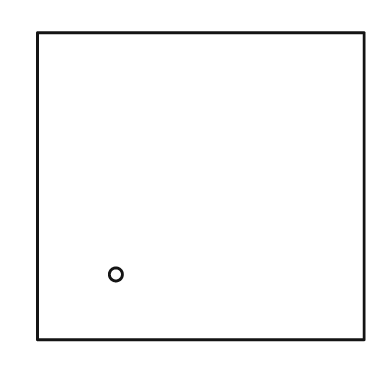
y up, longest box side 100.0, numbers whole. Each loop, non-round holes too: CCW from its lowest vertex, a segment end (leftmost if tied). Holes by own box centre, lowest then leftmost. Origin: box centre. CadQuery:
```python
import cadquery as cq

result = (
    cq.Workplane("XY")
    .moveTo(-50.0, -47.0)
    .lineTo(50.0, -47.0)
    .lineTo(50.0, 47.0)
    .lineTo(-50.0, 47.0)
    .close()
    .moveTo(-26.0, -27.0)
    .circle(2.0)
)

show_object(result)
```